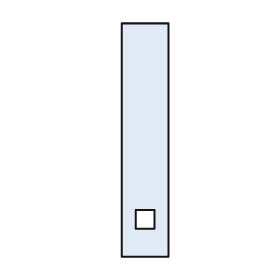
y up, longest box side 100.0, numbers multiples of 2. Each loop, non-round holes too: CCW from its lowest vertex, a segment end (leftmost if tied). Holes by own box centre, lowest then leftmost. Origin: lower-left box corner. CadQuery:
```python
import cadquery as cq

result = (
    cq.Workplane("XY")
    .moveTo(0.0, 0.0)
    .lineTo(20.0, 0.0)
    .lineTo(20.0, 100.0)
    .lineTo(0.0, 100.0)
    .close()
    .moveTo(6.0, 12.0)
    .lineTo(14.0, 12.0)
    .lineTo(14.0, 20.0)
    .lineTo(6.0, 20.0)
    .close()
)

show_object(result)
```